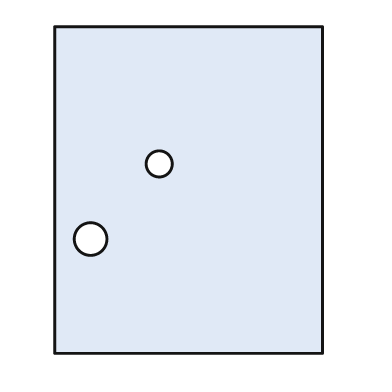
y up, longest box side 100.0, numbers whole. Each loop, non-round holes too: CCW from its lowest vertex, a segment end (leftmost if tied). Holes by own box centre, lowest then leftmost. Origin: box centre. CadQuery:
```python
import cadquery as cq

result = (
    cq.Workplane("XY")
    .moveTo(-41.0, -50.0)
    .lineTo(41.0, -50.0)
    .lineTo(41.0, 50.0)
    .lineTo(-41.0, 50.0)
    .close()
    .moveTo(-30.0, -15.0)
    .circle(5.0)
    .moveTo(-9.0, 8.0)
    .circle(4.0)
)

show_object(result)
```